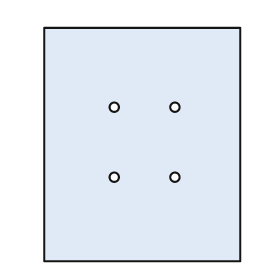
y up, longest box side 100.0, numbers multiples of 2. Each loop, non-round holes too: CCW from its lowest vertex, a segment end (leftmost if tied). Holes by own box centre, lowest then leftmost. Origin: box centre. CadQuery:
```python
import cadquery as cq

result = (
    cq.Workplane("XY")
    .moveTo(-42.0, -50.0)
    .lineTo(42.0, -50.0)
    .lineTo(42.0, 50.0)
    .lineTo(-42.0, 50.0)
    .close()
    .moveTo(-12.0, -14.0)
    .circle(2.0)
    .moveTo(14.0, -14.0)
    .circle(2.0)
    .moveTo(-12.0, 16.0)
    .circle(2.0)
    .moveTo(14.0, 16.0)
    .circle(2.0)
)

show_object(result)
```